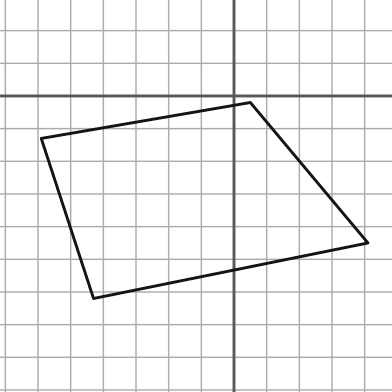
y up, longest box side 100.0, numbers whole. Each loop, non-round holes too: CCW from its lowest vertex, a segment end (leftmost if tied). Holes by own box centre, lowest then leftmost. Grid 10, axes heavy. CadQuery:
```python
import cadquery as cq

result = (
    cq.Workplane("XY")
    .moveTo(-43.0, -62.0)
    .lineTo(41.0, -45.0)
    .lineTo(5.0, -2.0)
    .lineTo(-59.0, -13.0)
    .close()
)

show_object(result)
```